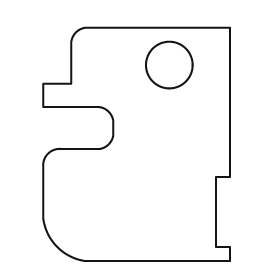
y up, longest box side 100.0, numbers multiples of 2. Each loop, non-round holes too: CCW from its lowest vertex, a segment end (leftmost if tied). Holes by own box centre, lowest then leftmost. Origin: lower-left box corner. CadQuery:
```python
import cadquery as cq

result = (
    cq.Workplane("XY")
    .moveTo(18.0, 0.0)
    .lineTo(80.0, 0.0)
    .lineTo(80.0, 6.0)
    .lineTo(74.0, 6.0)
    .lineTo(74.0, 36.0)
    .lineTo(80.0, 36.0)
    .lineTo(80.0, 100.0)
    .lineTo(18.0, 100.0)
    .threePointArc((14.0, 98.0), (12.0, 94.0))
    .lineTo(12.0, 76.0)
    .lineTo(0.0, 76.0)
    .lineTo(0.0, 66.0)
    .lineTo(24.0, 66.0)
    .threePointArc((28.0, 64.0), (30.0, 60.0))
    .lineTo(30.0, 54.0)
    .threePointArc((28.0, 50.0), (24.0, 48.0))
    .lineTo(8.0, 48.0)
    .threePointArc((2.0, 46.0), (0.0, 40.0))
    .lineTo(0.0, 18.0)
    .threePointArc((6.0, 6.0), (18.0, 0.0))
    .close()
    .moveTo(54.0, 84.0)
    .circle(10.0)
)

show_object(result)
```